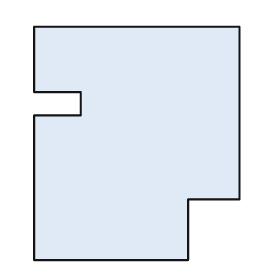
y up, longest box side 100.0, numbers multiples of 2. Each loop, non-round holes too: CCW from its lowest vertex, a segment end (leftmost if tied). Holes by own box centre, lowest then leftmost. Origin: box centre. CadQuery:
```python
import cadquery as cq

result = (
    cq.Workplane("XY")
    .moveTo(-44.0, -50.0)
    .lineTo(22.0, -50.0)
    .lineTo(22.0, -24.0)
    .lineTo(44.0, -24.0)
    .lineTo(44.0, 50.0)
    .lineTo(-44.0, 50.0)
    .lineTo(-44.0, 22.0)
    .lineTo(-24.0, 22.0)
    .lineTo(-24.0, 12.0)
    .lineTo(-44.0, 12.0)
    .close()
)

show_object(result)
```